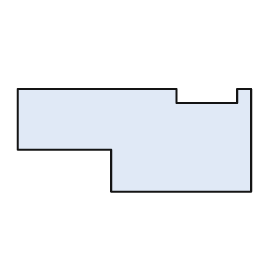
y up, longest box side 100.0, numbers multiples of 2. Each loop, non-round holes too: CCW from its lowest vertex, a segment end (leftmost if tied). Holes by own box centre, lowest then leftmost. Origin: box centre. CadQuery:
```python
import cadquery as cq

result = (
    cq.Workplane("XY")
    .moveTo(-10.0, -22.0)
    .lineTo(50.0, -22.0)
    .lineTo(50.0, 22.0)
    .lineTo(44.0, 22.0)
    .lineTo(44.0, 16.0)
    .lineTo(18.0, 16.0)
    .lineTo(18.0, 22.0)
    .lineTo(-50.0, 22.0)
    .lineTo(-50.0, -4.0)
    .lineTo(-10.0, -4.0)
    .close()
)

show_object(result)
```